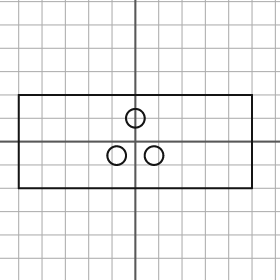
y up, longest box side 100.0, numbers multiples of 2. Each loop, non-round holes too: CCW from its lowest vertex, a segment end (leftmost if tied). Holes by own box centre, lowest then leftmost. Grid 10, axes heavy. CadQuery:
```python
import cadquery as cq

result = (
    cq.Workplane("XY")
    .moveTo(-50.0, -20.0)
    .lineTo(50.0, -20.0)
    .lineTo(50.0, 20.0)
    .lineTo(-50.0, 20.0)
    .close()
    .moveTo(-8.0, -6.0)
    .circle(4.0)
    .moveTo(8.0, -6.0)
    .circle(4.0)
    .moveTo(0.0, 10.0)
    .circle(4.0)
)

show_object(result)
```